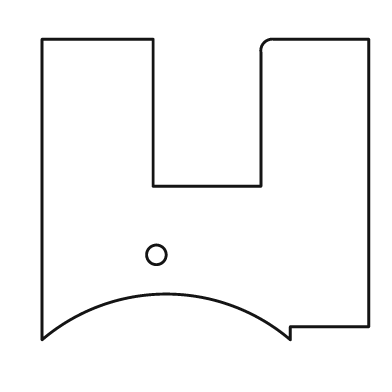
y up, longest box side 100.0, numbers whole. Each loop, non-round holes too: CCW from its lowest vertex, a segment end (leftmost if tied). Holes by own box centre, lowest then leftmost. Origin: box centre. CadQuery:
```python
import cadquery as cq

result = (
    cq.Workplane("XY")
    .moveTo(-50.0, -46.0)
    .threePointArc((-12.0, -32.0), (26.0, -46.0))
    .lineTo(26.0, -42.0)
    .lineTo(50.0, -42.0)
    .lineTo(50.0, 46.0)
    .lineTo(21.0, 46.0)
    .threePointArc((18.0, 45.0), (17.0, 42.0))
    .lineTo(17.0, 1.0)
    .lineTo(-16.0, 1.0)
    .lineTo(-16.0, 46.0)
    .lineTo(-50.0, 46.0)
    .close()
    .moveTo(-15.0, -20.0)
    .circle(3.0)
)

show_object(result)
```